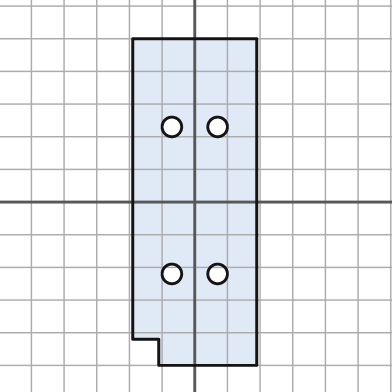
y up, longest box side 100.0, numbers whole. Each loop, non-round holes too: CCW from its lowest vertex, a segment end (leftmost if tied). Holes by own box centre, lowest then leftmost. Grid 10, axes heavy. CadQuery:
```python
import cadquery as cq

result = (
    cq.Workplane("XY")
    .moveTo(-11.0, -50.0)
    .lineTo(19.0, -50.0)
    .lineTo(19.0, 50.0)
    .lineTo(-19.0, 50.0)
    .lineTo(-19.0, -42.0)
    .lineTo(-11.0, -42.0)
    .close()
    .moveTo(-7.0, -22.0)
    .circle(3.0)
    .moveTo(7.0, -22.0)
    .circle(3.0)
    .moveTo(-7.0, 23.0)
    .circle(3.0)
    .moveTo(7.0, 23.0)
    .circle(3.0)
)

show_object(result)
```